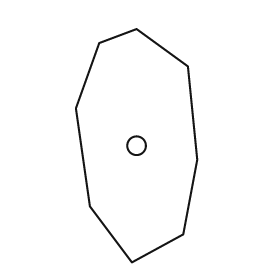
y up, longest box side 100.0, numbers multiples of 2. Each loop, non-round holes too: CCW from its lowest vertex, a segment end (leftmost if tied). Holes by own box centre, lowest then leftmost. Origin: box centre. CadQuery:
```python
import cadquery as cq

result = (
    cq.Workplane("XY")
    .moveTo(-2.0, -50.0)
    .lineTo(20.0, -38.0)
    .lineTo(26.0, -6.0)
    .lineTo(22.0, 34.0)
    .lineTo(0.0, 50.0)
    .lineTo(-16.0, 44.0)
    .lineTo(-26.0, 16.0)
    .lineTo(-20.0, -26.0)
    .close()
    .moveTo(0.0, 0.0)
    .circle(4.0)
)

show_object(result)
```